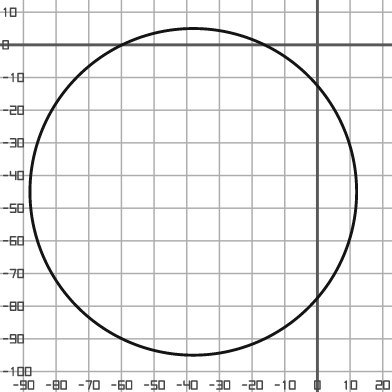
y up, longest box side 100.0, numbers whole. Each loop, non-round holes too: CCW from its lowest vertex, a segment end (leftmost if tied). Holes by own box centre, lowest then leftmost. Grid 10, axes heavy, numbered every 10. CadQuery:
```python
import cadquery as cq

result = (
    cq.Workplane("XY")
    .moveTo(-38.0, -45.0)
    .circle(50.0)
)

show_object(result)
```